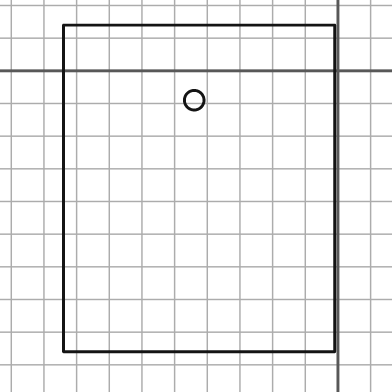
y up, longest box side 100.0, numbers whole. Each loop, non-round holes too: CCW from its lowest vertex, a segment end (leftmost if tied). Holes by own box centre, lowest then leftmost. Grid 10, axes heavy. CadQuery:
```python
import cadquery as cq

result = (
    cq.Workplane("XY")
    .moveTo(-84.0, -86.0)
    .lineTo(-1.0, -86.0)
    .lineTo(-1.0, 14.0)
    .lineTo(-84.0, 14.0)
    .close()
    .moveTo(-44.0, -9.0)
    .circle(3.0)
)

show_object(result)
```